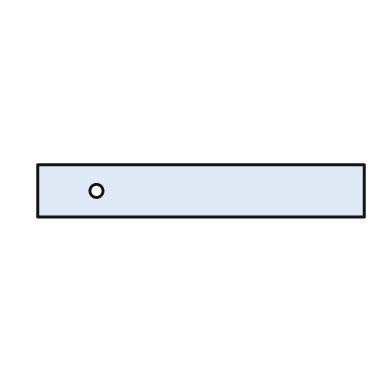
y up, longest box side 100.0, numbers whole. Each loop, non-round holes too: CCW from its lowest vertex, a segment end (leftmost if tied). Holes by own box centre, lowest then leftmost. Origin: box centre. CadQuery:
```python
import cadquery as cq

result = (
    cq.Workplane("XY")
    .moveTo(-50.0, -8.0)
    .lineTo(50.0, -8.0)
    .lineTo(50.0, 8.0)
    .lineTo(-50.0, 8.0)
    .close()
    .moveTo(-32.0, 0.0)
    .circle(2.0)
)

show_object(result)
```